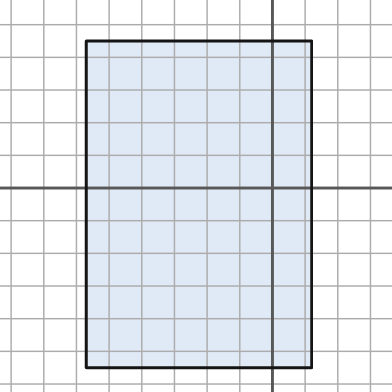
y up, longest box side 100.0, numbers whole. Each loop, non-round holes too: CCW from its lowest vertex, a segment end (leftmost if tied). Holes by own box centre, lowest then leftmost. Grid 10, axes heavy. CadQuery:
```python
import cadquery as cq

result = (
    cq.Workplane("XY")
    .moveTo(-57.0, -55.0)
    .lineTo(12.0, -55.0)
    .lineTo(12.0, 45.0)
    .lineTo(-57.0, 45.0)
    .close()
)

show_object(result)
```